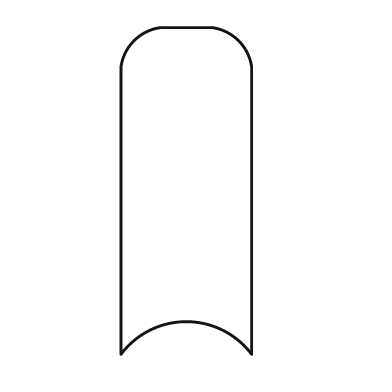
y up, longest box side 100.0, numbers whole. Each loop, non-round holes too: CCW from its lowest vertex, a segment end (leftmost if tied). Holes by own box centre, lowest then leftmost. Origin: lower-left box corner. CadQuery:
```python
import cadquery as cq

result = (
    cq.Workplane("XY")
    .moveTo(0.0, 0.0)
    .threePointArc((20.0, 10.0), (40.0, 0.0))
    .lineTo(40.0, 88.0)
    .threePointArc((36.0, 96.0), (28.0, 100.0))
    .lineTo(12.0, 100.0)
    .threePointArc((4.0, 96.0), (0.0, 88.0))
    .close()
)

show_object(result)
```